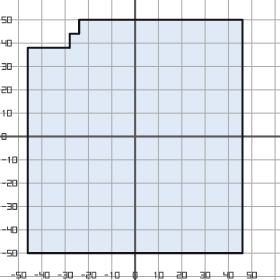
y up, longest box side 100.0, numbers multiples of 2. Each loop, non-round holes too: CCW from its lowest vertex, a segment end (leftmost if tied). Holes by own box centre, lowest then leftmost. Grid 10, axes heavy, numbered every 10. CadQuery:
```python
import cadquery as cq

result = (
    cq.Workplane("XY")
    .moveTo(-46.0, -50.0)
    .lineTo(46.0, -50.0)
    .lineTo(46.0, 50.0)
    .lineTo(-24.0, 50.0)
    .lineTo(-24.0, 44.0)
    .lineTo(-28.0, 44.0)
    .lineTo(-28.0, 38.0)
    .lineTo(-46.0, 38.0)
    .close()
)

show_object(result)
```